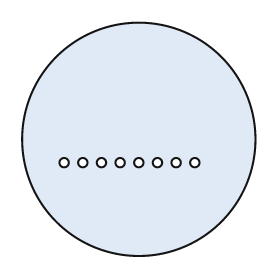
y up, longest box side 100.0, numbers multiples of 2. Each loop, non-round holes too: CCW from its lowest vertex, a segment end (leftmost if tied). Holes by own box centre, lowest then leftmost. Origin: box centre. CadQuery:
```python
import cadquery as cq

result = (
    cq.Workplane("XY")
    .moveTo(0.0, 0.0)
    .circle(50.0)
    .moveTo(-32.0, -10.0)
    .circle(2.0)
    .moveTo(-24.0, -10.0)
    .circle(2.0)
    .moveTo(-16.0, -10.0)
    .circle(2.0)
    .moveTo(-8.0, -10.0)
    .circle(2.0)
    .moveTo(0.0, -10.0)
    .circle(2.0)
    .moveTo(8.0, -10.0)
    .circle(2.0)
    .moveTo(16.0, -10.0)
    .circle(2.0)
    .moveTo(24.0, -10.0)
    .circle(2.0)
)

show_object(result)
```